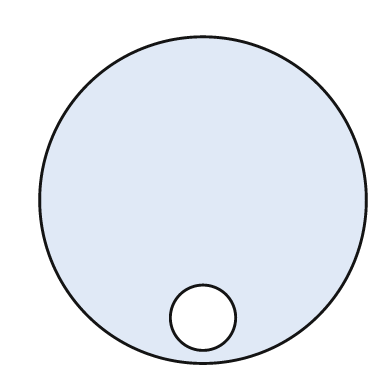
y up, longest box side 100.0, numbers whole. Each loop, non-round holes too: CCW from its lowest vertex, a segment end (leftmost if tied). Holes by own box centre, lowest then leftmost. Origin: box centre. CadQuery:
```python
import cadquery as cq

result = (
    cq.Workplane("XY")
    .moveTo(0.0, 0.0)
    .circle(50.0)
    .moveTo(0.0, -36.0)
    .circle(10.0)
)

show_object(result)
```